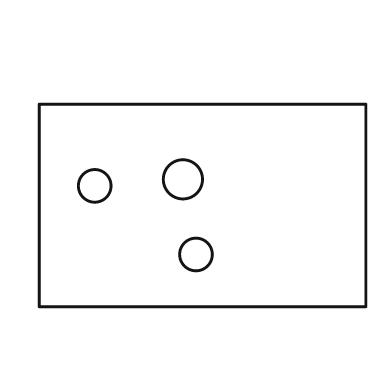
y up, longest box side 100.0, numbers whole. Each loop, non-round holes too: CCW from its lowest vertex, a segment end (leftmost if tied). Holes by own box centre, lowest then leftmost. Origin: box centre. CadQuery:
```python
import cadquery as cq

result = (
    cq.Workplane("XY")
    .moveTo(-50.0, -31.0)
    .lineTo(50.0, -31.0)
    .lineTo(50.0, 31.0)
    .lineTo(-50.0, 31.0)
    .close()
    .moveTo(-2.0, -15.0)
    .circle(5.0)
    .moveTo(-33.0, 6.0)
    .circle(5.0)
    .moveTo(-6.0, 8.0)
    .circle(6.0)
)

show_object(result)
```